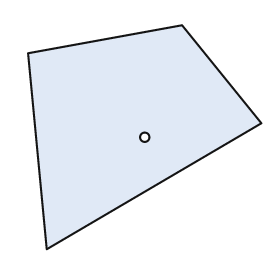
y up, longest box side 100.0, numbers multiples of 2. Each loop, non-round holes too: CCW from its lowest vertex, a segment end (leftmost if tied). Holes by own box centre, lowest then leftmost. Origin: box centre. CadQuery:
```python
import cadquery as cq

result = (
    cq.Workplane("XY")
    .moveTo(-42.0, -48.0)
    .lineTo(50.0, 6.0)
    .lineTo(16.0, 48.0)
    .lineTo(-50.0, 36.0)
    .close()
    .moveTo(0.0, 0.0)
    .circle(2.0)
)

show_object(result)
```